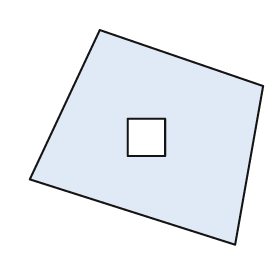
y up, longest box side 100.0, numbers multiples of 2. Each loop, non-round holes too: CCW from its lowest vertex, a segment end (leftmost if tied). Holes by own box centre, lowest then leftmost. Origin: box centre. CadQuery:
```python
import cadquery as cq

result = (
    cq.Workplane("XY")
    .moveTo(38.0, -46.0)
    .lineTo(50.0, 22.0)
    .lineTo(-20.0, 46.0)
    .lineTo(-50.0, -18.0)
    .close()
    .moveTo(-8.0, -8.0)
    .lineTo(8.0, -8.0)
    .lineTo(8.0, 8.0)
    .lineTo(-8.0, 8.0)
    .close()
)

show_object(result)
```